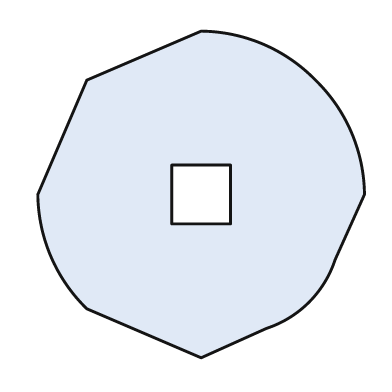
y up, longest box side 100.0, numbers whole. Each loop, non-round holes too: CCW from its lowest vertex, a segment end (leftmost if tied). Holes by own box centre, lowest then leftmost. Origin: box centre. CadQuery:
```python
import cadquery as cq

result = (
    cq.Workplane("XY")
    .moveTo(0.0, -50.0)
    .lineTo(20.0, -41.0)
    .threePointArc((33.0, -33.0), (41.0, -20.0))
    .lineTo(50.0, 0.0)
    .threePointArc((46.0, 19.0), (35.0, 35.0))
    .threePointArc((19.0, 46.0), (0.0, 50.0))
    .lineTo(-35.0, 35.0)
    .lineTo(-50.0, 0.0)
    .threePointArc((-46.0, -19.0), (-35.0, -35.0))
    .close()
    .moveTo(-9.0, -9.0)
    .lineTo(9.0, -9.0)
    .lineTo(9.0, 9.0)
    .lineTo(-9.0, 9.0)
    .close()
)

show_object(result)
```